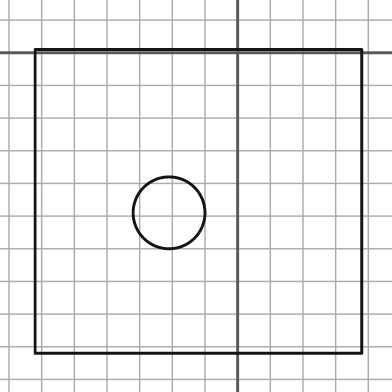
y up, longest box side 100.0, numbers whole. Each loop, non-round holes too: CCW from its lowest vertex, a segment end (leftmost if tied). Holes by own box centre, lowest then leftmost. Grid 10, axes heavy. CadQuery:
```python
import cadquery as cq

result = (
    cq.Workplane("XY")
    .moveTo(-62.0, -92.0)
    .lineTo(38.0, -92.0)
    .lineTo(38.0, 1.0)
    .lineTo(-62.0, 1.0)
    .close()
    .moveTo(-21.0, -49.0)
    .circle(11.0)
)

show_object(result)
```